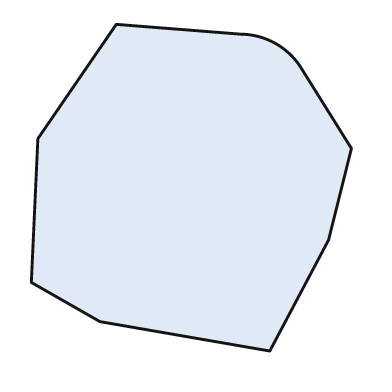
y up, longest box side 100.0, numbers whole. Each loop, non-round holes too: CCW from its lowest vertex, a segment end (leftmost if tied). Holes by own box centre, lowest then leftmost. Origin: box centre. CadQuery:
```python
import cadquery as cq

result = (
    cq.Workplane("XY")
    .moveTo(24.0, -50.0)
    .lineTo(42.0, -16.0)
    .lineTo(49.0, 12.0)
    .lineTo(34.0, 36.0)
    .threePointArc((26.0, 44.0), (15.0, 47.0))
    .lineTo(-23.0, 50.0)
    .lineTo(-47.0, 15.0)
    .lineTo(-49.0, -29.0)
    .lineTo(-28.0, -41.0)
    .close()
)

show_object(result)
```